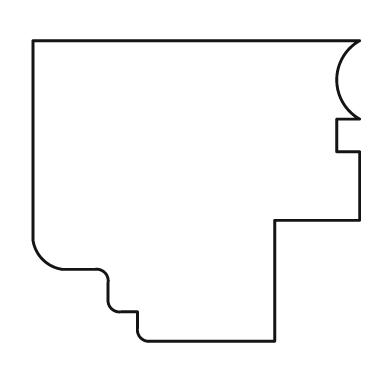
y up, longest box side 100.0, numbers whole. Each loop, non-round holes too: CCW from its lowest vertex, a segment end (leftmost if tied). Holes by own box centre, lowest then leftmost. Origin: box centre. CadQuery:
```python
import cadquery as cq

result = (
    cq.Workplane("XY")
    .moveTo(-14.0, -46.0)
    .lineTo(24.0, -46.0)
    .lineTo(24.0, -9.0)
    .lineTo(50.0, -9.0)
    .lineTo(50.0, 12.0)
    .lineTo(43.0, 12.0)
    .lineTo(43.0, 22.0)
    .lineTo(50.0, 22.0)
    .threePointArc((43.0, 34.0), (50.0, 46.0))
    .lineTo(-50.0, 46.0)
    .lineTo(-50.0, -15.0)
    .threePointArc((-47.0, -21.0), (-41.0, -24.0))
    .lineTo(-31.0, -24.0)
    .threePointArc((-28.0, -25.0), (-27.0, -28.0))
    .lineTo(-27.0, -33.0)
    .threePointArc((-26.0, -36.0), (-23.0, -37.0))
    .lineTo(-18.0, -37.0)
    .lineTo(-18.0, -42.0)
    .threePointArc((-17.0, -45.0), (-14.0, -46.0))
    .close()
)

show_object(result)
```